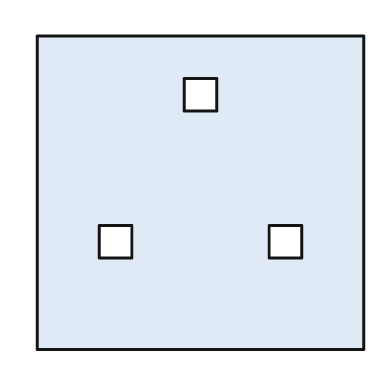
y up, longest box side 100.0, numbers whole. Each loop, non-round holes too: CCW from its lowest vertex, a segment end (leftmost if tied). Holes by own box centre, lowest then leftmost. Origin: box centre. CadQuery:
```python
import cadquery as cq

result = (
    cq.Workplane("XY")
    .moveTo(-50.0, -48.0)
    .lineTo(50.0, -48.0)
    .lineTo(50.0, 48.0)
    .lineTo(-50.0, 48.0)
    .close()
    .moveTo(-31.0, -20.0)
    .lineTo(-21.0, -20.0)
    .lineTo(-21.0, -10.0)
    .lineTo(-31.0, -10.0)
    .close()
    .moveTo(21.0, -20.0)
    .lineTo(31.0, -20.0)
    .lineTo(31.0, -10.0)
    .lineTo(21.0, -10.0)
    .close()
    .moveTo(-5.0, 25.0)
    .lineTo(5.0, 25.0)
    .lineTo(5.0, 35.0)
    .lineTo(-5.0, 35.0)
    .close()
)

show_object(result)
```